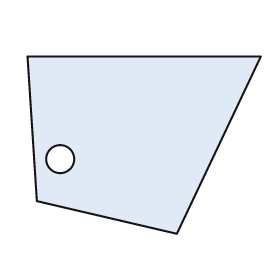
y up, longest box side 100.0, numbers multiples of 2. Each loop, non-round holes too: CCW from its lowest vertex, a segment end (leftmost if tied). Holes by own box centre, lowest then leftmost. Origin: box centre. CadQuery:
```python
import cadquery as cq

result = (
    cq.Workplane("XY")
    .moveTo(14.0, -38.0)
    .lineTo(50.0, 38.0)
    .lineTo(-50.0, 38.0)
    .lineTo(-46.0, -24.0)
    .close()
    .moveTo(-36.0, -6.0)
    .circle(6.0)
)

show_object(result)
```